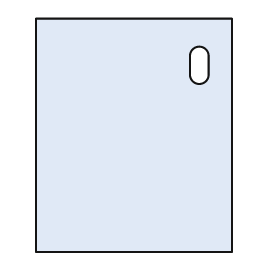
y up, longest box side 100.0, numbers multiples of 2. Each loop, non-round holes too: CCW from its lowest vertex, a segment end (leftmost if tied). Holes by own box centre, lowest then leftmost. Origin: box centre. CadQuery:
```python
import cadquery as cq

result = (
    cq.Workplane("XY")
    .moveTo(-42.0, -50.0)
    .lineTo(42.0, -50.0)
    .lineTo(42.0, 50.0)
    .lineTo(-42.0, 50.0)
    .close()
    .moveTo(24.0, 26.0)
    .threePointArc((28.0, 22.0), (32.0, 26.0))
    .lineTo(32.0, 34.0)
    .threePointArc((28.0, 38.0), (24.0, 34.0))
    .close()
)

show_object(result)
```